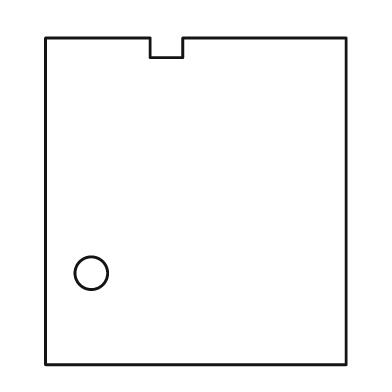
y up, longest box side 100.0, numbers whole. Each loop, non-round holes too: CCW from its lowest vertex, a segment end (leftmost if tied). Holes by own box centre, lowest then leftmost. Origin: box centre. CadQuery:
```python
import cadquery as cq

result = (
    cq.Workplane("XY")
    .moveTo(-46.0, -50.0)
    .lineTo(46.0, -50.0)
    .lineTo(46.0, 50.0)
    .lineTo(-4.0, 50.0)
    .lineTo(-4.0, 44.0)
    .lineTo(-14.0, 44.0)
    .lineTo(-14.0, 50.0)
    .lineTo(-46.0, 50.0)
    .close()
    .moveTo(-32.0, -22.0)
    .circle(5.0)
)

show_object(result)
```